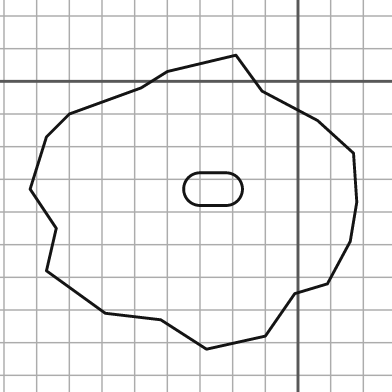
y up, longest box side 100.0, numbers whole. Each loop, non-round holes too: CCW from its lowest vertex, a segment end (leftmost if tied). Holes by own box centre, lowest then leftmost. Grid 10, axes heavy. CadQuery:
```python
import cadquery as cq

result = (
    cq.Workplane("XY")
    .moveTo(-28.0, -82.0)
    .lineTo(-10.0, -78.0)
    .lineTo(-1.0, -65.0)
    .lineTo(9.0, -62.0)
    .lineTo(16.0, -49.0)
    .lineTo(18.0, -37.0)
    .lineTo(17.0, -22.0)
    .lineTo(6.0, -12.0)
    .lineTo(-11.0, -3.0)
    .lineTo(-19.0, 8.0)
    .lineTo(-40.0, 3.0)
    .lineTo(-48.0, -2.0)
    .lineTo(-70.0, -10.0)
    .lineTo(-77.0, -17.0)
    .lineTo(-82.0, -33.0)
    .lineTo(-74.0, -45.0)
    .lineTo(-77.0, -58.0)
    .lineTo(-59.0, -71.0)
    .lineTo(-42.0, -73.0)
    .close()
    .moveTo(-30.0, -38.0)
    .lineTo(-22.0, -38.0)
    .threePointArc((-17.0, -33.0), (-22.0, -28.0))
    .lineTo(-30.0, -28.0)
    .threePointArc((-35.0, -33.0), (-30.0, -38.0))
    .close()
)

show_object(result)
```